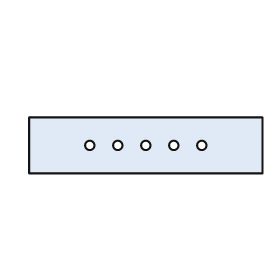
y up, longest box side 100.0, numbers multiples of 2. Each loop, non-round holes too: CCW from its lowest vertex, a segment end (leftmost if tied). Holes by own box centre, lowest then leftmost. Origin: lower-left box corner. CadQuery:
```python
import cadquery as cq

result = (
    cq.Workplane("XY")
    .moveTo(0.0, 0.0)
    .lineTo(100.0, 0.0)
    .lineTo(100.0, 24.0)
    .lineTo(0.0, 24.0)
    .close()
    .moveTo(26.0, 12.0)
    .circle(2.0)
    .moveTo(38.0, 12.0)
    .circle(2.0)
    .moveTo(50.0, 12.0)
    .circle(2.0)
    .moveTo(62.0, 12.0)
    .circle(2.0)
    .moveTo(74.0, 12.0)
    .circle(2.0)
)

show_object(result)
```